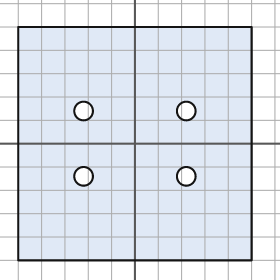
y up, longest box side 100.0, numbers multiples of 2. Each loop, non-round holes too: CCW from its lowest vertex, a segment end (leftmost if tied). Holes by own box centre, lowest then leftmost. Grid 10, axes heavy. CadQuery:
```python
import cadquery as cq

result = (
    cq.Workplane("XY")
    .moveTo(-50.0, -50.0)
    .lineTo(50.0, -50.0)
    .lineTo(50.0, 50.0)
    .lineTo(-50.0, 50.0)
    .close()
    .moveTo(-22.0, -14.0)
    .circle(4.0)
    .moveTo(22.0, -14.0)
    .circle(4.0)
    .moveTo(-22.0, 14.0)
    .circle(4.0)
    .moveTo(22.0, 14.0)
    .circle(4.0)
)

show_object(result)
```